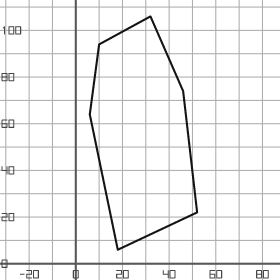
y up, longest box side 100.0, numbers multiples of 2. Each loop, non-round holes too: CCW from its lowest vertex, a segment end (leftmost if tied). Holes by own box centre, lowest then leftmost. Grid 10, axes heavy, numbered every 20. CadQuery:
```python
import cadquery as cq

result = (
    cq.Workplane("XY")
    .moveTo(18.0, 6.0)
    .lineTo(52.0, 22.0)
    .lineTo(46.0, 74.0)
    .lineTo(32.0, 106.0)
    .lineTo(10.0, 94.0)
    .lineTo(6.0, 64.0)
    .close()
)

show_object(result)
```